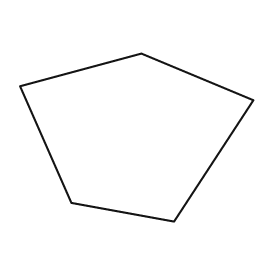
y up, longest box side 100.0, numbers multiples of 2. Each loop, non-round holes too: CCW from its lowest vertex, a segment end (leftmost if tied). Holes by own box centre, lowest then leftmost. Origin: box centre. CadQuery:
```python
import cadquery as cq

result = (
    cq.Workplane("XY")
    .moveTo(16.0, -36.0)
    .lineTo(50.0, 16.0)
    .lineTo(2.0, 36.0)
    .lineTo(-50.0, 22.0)
    .lineTo(-28.0, -28.0)
    .close()
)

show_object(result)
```